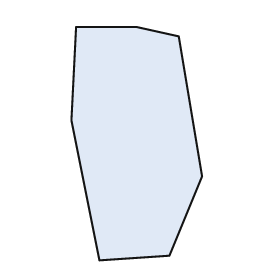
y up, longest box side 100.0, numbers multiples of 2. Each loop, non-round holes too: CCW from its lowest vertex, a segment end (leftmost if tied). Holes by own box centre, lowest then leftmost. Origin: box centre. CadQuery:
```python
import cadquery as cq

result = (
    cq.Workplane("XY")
    .moveTo(-16.0, -50.0)
    .lineTo(14.0, -48.0)
    .lineTo(28.0, -14.0)
    .lineTo(18.0, 46.0)
    .lineTo(0.0, 50.0)
    .lineTo(-26.0, 50.0)
    .lineTo(-28.0, 10.0)
    .close()
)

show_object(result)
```